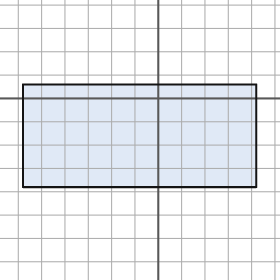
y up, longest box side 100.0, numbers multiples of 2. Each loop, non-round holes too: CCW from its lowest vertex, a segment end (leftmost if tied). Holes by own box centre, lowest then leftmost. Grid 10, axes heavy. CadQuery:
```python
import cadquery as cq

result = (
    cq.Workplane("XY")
    .moveTo(-58.0, -38.0)
    .lineTo(42.0, -38.0)
    .lineTo(42.0, 6.0)
    .lineTo(-58.0, 6.0)
    .close()
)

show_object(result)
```